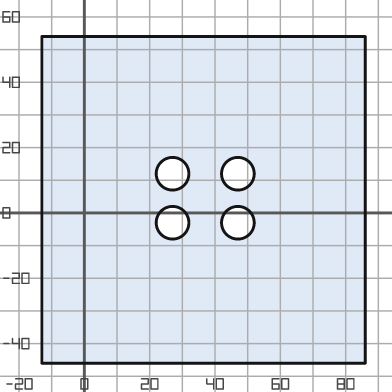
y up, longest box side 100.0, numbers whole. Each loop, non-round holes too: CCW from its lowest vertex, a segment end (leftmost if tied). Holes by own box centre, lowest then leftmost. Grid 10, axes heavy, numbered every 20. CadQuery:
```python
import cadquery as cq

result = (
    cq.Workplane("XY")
    .moveTo(-13.0, -46.0)
    .lineTo(86.0, -46.0)
    .lineTo(86.0, 54.0)
    .lineTo(-13.0, 54.0)
    .close()
    .moveTo(27.0, -3.0)
    .circle(5.0)
    .moveTo(47.0, -3.0)
    .circle(5.0)
    .moveTo(27.0, 12.0)
    .circle(5.0)
    .moveTo(47.0, 12.0)
    .circle(5.0)
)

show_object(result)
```